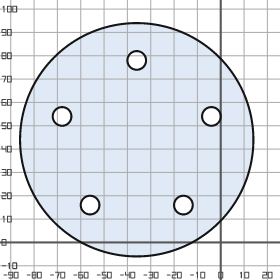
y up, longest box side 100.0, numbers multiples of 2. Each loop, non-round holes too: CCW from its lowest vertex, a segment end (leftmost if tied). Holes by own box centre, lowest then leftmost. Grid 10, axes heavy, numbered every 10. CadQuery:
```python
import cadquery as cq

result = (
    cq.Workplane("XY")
    .moveTo(-36.0, 44.0)
    .circle(50.0)
    .moveTo(-56.0, 16.0)
    .circle(4.0)
    .moveTo(-16.0, 16.0)
    .circle(4.0)
    .moveTo(-68.0, 54.0)
    .circle(4.0)
    .moveTo(-4.0, 54.0)
    .circle(4.0)
    .moveTo(-36.0, 78.0)
    .circle(4.0)
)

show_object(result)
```